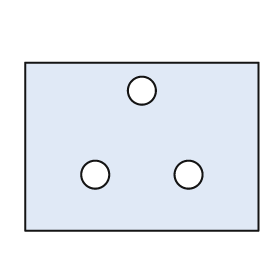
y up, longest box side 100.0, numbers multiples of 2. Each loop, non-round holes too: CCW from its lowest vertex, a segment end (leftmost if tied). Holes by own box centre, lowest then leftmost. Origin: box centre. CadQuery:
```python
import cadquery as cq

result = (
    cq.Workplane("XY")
    .moveTo(-50.0, -36.0)
    .lineTo(50.0, -36.0)
    .lineTo(50.0, 36.0)
    .lineTo(-50.0, 36.0)
    .close()
    .moveTo(-20.0, -12.0)
    .circle(6.0)
    .moveTo(20.0, -12.0)
    .circle(6.0)
    .moveTo(0.0, 24.0)
    .circle(6.0)
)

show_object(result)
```